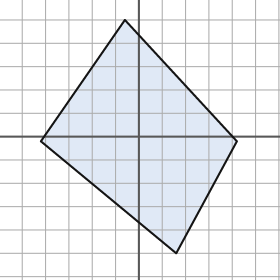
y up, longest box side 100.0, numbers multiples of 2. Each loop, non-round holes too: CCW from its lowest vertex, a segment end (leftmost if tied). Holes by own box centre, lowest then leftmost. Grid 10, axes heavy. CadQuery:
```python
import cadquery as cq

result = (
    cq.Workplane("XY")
    .moveTo(16.0, -50.0)
    .lineTo(42.0, -2.0)
    .lineTo(-6.0, 50.0)
    .lineTo(-42.0, -2.0)
    .close()
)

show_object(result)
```